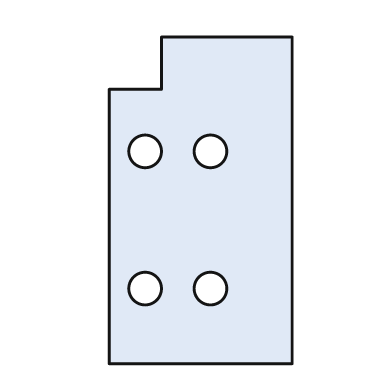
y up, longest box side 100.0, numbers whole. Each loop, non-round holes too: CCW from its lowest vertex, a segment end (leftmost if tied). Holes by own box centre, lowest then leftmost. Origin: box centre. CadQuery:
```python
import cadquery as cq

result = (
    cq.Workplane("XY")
    .moveTo(-28.0, -50.0)
    .lineTo(28.0, -50.0)
    .lineTo(28.0, 50.0)
    .lineTo(-12.0, 50.0)
    .lineTo(-12.0, 34.0)
    .lineTo(-28.0, 34.0)
    .close()
    .moveTo(-17.0, -27.0)
    .circle(5.0)
    .moveTo(3.0, -27.0)
    .circle(5.0)
    .moveTo(-17.0, 15.0)
    .circle(5.0)
    .moveTo(3.0, 15.0)
    .circle(5.0)
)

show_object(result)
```